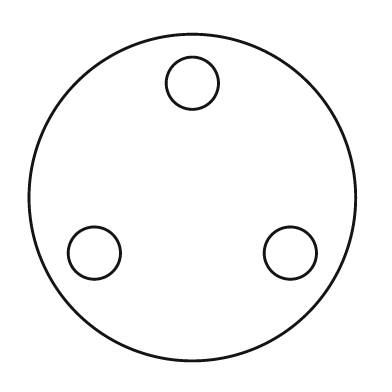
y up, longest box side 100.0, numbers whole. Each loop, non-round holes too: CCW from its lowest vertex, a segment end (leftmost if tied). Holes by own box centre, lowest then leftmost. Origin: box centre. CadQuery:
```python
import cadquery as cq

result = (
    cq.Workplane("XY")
    .moveTo(0.0, 0.0)
    .circle(50.0)
    .moveTo(-30.0, -17.0)
    .circle(8.0)
    .moveTo(30.0, -17.0)
    .circle(8.0)
    .moveTo(0.0, 35.0)
    .circle(8.0)
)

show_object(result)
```